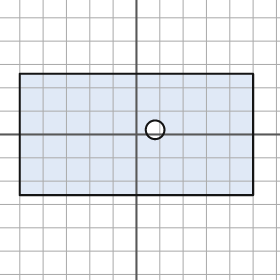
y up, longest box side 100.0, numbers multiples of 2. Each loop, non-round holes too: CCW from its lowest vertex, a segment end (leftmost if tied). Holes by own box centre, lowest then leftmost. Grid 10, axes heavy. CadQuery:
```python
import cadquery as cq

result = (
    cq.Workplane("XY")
    .moveTo(-50.0, -26.0)
    .lineTo(50.0, -26.0)
    .lineTo(50.0, 26.0)
    .lineTo(-50.0, 26.0)
    .close()
    .moveTo(8.0, 2.0)
    .circle(4.0)
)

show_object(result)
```